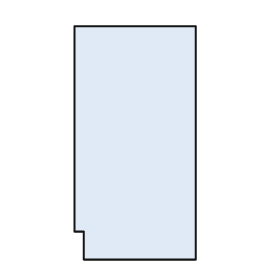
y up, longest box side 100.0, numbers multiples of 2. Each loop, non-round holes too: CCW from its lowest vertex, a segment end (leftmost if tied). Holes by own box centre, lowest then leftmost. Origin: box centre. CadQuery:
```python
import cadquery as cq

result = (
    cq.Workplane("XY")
    .moveTo(-22.0, -50.0)
    .lineTo(26.0, -50.0)
    .lineTo(26.0, 50.0)
    .lineTo(-26.0, 50.0)
    .lineTo(-26.0, -38.0)
    .lineTo(-22.0, -38.0)
    .close()
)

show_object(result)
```